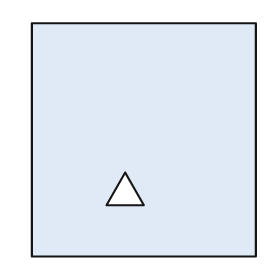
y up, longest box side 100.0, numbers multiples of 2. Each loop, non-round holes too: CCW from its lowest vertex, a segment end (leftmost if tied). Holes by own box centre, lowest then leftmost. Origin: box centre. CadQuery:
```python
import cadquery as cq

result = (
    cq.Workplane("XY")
    .moveTo(-48.0, -50.0)
    .lineTo(48.0, -50.0)
    .lineTo(48.0, 50.0)
    .lineTo(-48.0, 50.0)
    .close()
    .moveTo(-16.0, -28.0)
    .lineTo(0.0, -28.0)
    .lineTo(-8.0, -14.0)
    .close()
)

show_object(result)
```